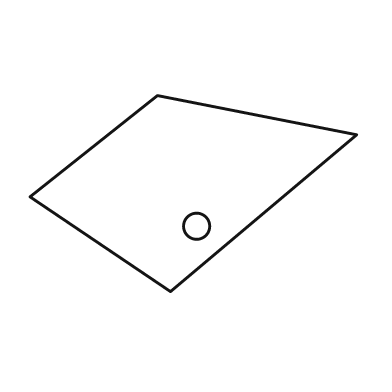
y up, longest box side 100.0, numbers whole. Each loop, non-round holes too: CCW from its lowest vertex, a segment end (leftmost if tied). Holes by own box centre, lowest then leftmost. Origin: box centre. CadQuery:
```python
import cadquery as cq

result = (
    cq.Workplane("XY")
    .moveTo(-7.0, -30.0)
    .lineTo(50.0, 18.0)
    .lineTo(-11.0, 30.0)
    .lineTo(-50.0, -1.0)
    .close()
    .moveTo(1.0, -10.0)
    .circle(4.0)
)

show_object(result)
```